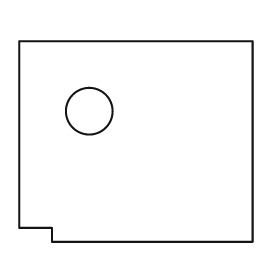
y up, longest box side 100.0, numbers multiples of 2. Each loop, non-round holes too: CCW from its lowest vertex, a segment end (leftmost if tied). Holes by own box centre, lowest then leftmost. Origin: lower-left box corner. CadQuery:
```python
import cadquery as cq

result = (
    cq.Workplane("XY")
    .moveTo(14.0, 0.0)
    .lineTo(100.0, 0.0)
    .lineTo(100.0, 86.0)
    .lineTo(0.0, 86.0)
    .lineTo(0.0, 6.0)
    .lineTo(14.0, 6.0)
    .close()
    .moveTo(30.0, 56.0)
    .circle(10.0)
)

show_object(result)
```